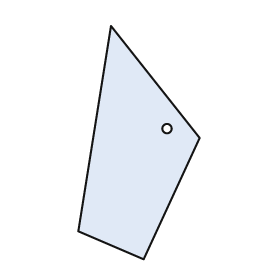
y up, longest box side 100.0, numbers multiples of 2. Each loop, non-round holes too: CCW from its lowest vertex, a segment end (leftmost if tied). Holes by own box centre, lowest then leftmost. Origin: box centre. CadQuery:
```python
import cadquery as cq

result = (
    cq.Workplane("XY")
    .moveTo(2.0, -50.0)
    .lineTo(26.0, 2.0)
    .lineTo(-12.0, 50.0)
    .lineTo(-26.0, -38.0)
    .close()
    .moveTo(12.0, 6.0)
    .circle(2.0)
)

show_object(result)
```